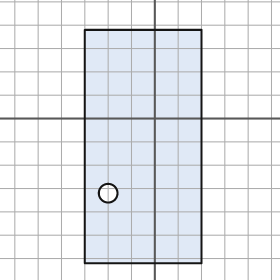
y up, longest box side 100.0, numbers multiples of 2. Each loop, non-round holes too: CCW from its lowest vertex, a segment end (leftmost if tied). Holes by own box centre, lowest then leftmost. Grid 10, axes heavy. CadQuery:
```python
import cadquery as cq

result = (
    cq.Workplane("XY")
    .moveTo(-30.0, -62.0)
    .lineTo(20.0, -62.0)
    .lineTo(20.0, 38.0)
    .lineTo(-30.0, 38.0)
    .close()
    .moveTo(-20.0, -32.0)
    .circle(4.0)
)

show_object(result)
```